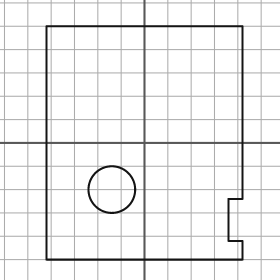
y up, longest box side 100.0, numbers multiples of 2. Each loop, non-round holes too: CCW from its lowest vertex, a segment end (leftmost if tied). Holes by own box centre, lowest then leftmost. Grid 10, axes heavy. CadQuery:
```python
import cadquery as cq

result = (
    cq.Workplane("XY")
    .moveTo(-42.0, -50.0)
    .lineTo(42.0, -50.0)
    .lineTo(42.0, -42.0)
    .lineTo(36.0, -42.0)
    .lineTo(36.0, -24.0)
    .lineTo(42.0, -24.0)
    .lineTo(42.0, 50.0)
    .lineTo(-42.0, 50.0)
    .close()
    .moveTo(-14.0, -20.0)
    .circle(10.0)
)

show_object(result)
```